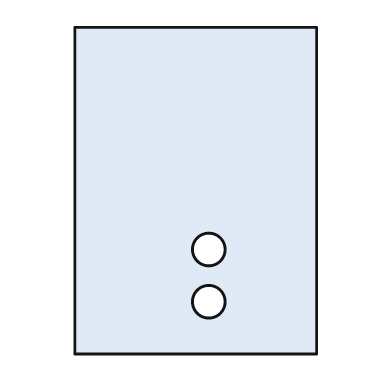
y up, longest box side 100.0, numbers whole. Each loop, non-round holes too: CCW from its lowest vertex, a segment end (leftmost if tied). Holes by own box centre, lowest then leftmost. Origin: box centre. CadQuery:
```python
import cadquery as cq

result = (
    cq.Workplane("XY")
    .moveTo(-37.0, -50.0)
    .lineTo(37.0, -50.0)
    .lineTo(37.0, 50.0)
    .lineTo(-37.0, 50.0)
    .close()
    .moveTo(4.0, -34.0)
    .circle(5.0)
    .moveTo(4.0, -18.0)
    .circle(5.0)
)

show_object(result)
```